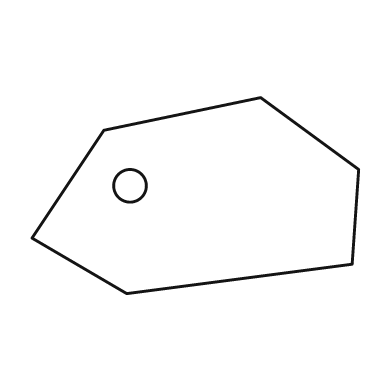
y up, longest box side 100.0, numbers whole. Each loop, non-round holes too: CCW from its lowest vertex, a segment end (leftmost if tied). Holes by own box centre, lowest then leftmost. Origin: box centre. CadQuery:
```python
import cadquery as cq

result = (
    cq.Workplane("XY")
    .moveTo(-21.0, -30.0)
    .lineTo(48.0, -21.0)
    .lineTo(50.0, 8.0)
    .lineTo(20.0, 30.0)
    .lineTo(-28.0, 20.0)
    .lineTo(-50.0, -13.0)
    .close()
    .moveTo(-20.0, 3.0)
    .circle(5.0)
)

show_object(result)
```